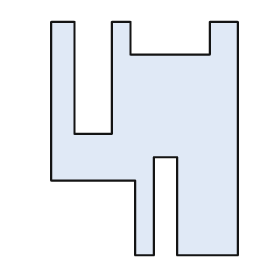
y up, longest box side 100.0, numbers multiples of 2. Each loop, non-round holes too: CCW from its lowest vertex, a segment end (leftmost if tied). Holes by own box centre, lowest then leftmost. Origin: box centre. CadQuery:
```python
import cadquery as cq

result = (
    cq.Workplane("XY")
    .moveTo(-4.0, -50.0)
    .lineTo(4.0, -50.0)
    .lineTo(4.0, -8.0)
    .lineTo(14.0, -8.0)
    .lineTo(14.0, -50.0)
    .lineTo(40.0, -50.0)
    .lineTo(40.0, 50.0)
    .lineTo(28.0, 50.0)
    .lineTo(28.0, 36.0)
    .lineTo(-6.0, 36.0)
    .lineTo(-6.0, 50.0)
    .lineTo(-14.0, 50.0)
    .lineTo(-14.0, 2.0)
    .lineTo(-30.0, 2.0)
    .lineTo(-30.0, 50.0)
    .lineTo(-40.0, 50.0)
    .lineTo(-40.0, -18.0)
    .lineTo(-4.0, -18.0)
    .close()
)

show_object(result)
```